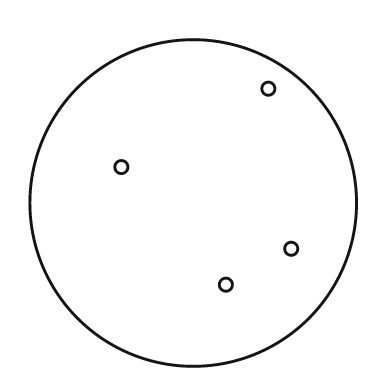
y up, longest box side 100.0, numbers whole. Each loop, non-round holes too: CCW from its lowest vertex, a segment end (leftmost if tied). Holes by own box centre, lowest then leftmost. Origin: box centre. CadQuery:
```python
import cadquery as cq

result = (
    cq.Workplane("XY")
    .moveTo(0.0, 0.0)
    .circle(50.0)
    .moveTo(10.0, -25.0)
    .circle(2.0)
    .moveTo(30.0, -14.0)
    .circle(2.0)
    .moveTo(-22.0, 11.0)
    .circle(2.0)
    .moveTo(23.0, 35.0)
    .circle(2.0)
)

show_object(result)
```